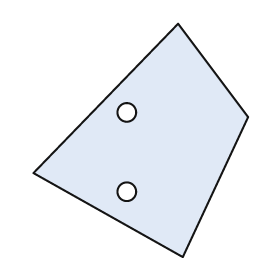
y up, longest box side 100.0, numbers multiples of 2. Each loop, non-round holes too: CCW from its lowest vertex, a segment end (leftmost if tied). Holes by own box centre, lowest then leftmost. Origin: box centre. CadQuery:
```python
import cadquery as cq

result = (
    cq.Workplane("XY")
    .moveTo(18.0, -50.0)
    .lineTo(46.0, 10.0)
    .lineTo(16.0, 50.0)
    .lineTo(-46.0, -14.0)
    .close()
    .moveTo(-6.0, -22.0)
    .circle(4.0)
    .moveTo(-6.0, 12.0)
    .circle(4.0)
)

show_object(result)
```